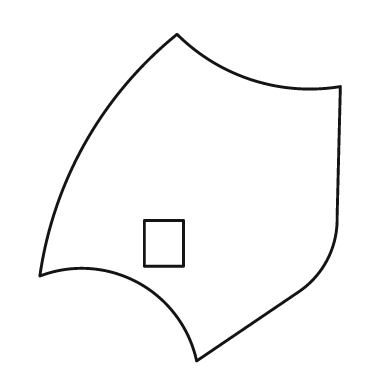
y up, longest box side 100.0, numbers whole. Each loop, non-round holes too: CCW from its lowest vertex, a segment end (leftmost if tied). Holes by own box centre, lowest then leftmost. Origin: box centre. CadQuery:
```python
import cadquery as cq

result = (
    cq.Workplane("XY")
    .moveTo(2.0, -50.0)
    .lineTo(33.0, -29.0)
    .threePointArc((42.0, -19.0), (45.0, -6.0))
    .lineTo(46.0, 34.0)
    .threePointArc((19.0, 36.0), (-4.0, 50.0))
    .threePointArc((-32.0, 17.0), (-46.0, -24.0))
    .threePointArc((-16.0, -26.0), (2.0, -50.0))
    .close()
    .moveTo(-14.0, -21.0)
    .lineTo(-2.0, -21.0)
    .lineTo(-2.0, -7.0)
    .lineTo(-14.0, -7.0)
    .close()
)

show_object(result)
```